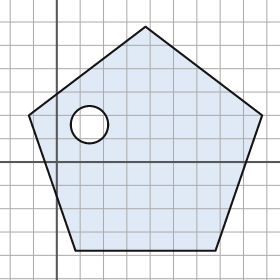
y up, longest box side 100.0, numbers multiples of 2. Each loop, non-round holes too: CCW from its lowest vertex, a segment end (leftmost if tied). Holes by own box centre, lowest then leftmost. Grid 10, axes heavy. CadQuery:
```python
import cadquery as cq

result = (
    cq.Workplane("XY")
    .moveTo(8.0, -38.0)
    .lineTo(68.0, -38.0)
    .lineTo(88.0, 20.0)
    .lineTo(38.0, 58.0)
    .lineTo(-12.0, 20.0)
    .close()
    .moveTo(14.0, 16.0)
    .circle(8.0)
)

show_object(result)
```